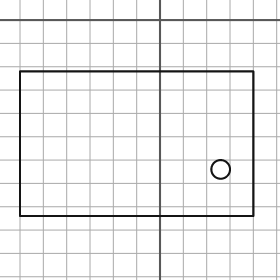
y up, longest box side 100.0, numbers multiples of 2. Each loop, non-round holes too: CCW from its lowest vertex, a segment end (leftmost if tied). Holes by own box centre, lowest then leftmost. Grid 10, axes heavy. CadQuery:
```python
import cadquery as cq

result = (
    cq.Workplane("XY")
    .moveTo(-60.0, -84.0)
    .lineTo(40.0, -84.0)
    .lineTo(40.0, -22.0)
    .lineTo(-60.0, -22.0)
    .close()
    .moveTo(26.0, -64.0)
    .circle(4.0)
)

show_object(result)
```